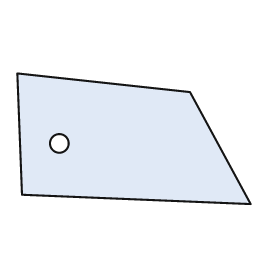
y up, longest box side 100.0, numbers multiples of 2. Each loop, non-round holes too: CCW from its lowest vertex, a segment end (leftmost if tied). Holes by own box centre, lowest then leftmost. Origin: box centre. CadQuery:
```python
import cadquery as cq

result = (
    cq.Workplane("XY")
    .moveTo(50.0, -28.0)
    .lineTo(24.0, 20.0)
    .lineTo(-50.0, 28.0)
    .lineTo(-48.0, -24.0)
    .close()
    .moveTo(-32.0, -2.0)
    .circle(4.0)
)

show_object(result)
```